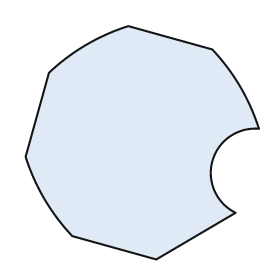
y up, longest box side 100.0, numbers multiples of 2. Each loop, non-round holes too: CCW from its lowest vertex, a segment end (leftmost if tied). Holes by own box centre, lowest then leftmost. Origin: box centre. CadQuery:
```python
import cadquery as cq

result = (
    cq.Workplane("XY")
    .moveTo(6.0, -50.0)
    .lineTo(40.0, -30.0)
    .threePointArc((30.0, -8.0), (50.0, 6.0))
    .threePointArc((42.0, 24.0), (30.0, 40.0))
    .lineTo(-6.0, 50.0)
    .threePointArc((-24.0, 42.0), (-40.0, 30.0))
    .lineTo(-50.0, -6.0)
    .threePointArc((-42.0, -24.0), (-30.0, -40.0))
    .close()
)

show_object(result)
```